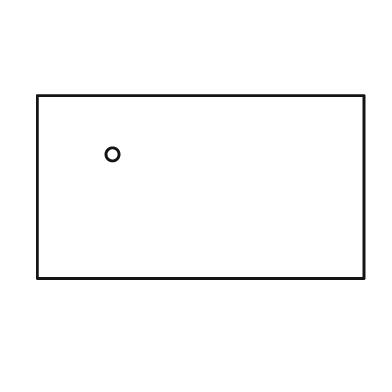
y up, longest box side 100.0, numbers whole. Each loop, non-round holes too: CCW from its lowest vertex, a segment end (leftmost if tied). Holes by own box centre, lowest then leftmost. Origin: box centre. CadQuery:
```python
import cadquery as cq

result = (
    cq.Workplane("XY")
    .moveTo(-50.0, -28.0)
    .lineTo(50.0, -28.0)
    .lineTo(50.0, 28.0)
    .lineTo(-50.0, 28.0)
    .close()
    .moveTo(-27.0, 10.0)
    .circle(2.0)
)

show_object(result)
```